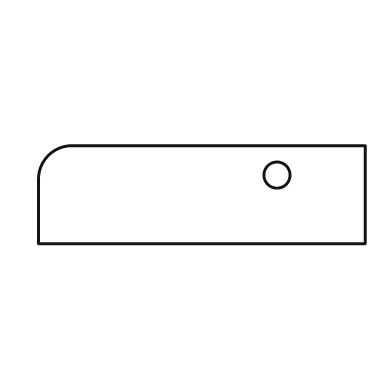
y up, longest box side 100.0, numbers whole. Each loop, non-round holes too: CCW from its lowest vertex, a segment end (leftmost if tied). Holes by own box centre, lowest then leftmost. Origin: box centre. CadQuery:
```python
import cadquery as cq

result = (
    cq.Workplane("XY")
    .moveTo(-50.0, -15.0)
    .lineTo(50.0, -15.0)
    .lineTo(50.0, 15.0)
    .lineTo(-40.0, 15.0)
    .threePointArc((-47.0, 12.0), (-50.0, 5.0))
    .close()
    .moveTo(23.0, 6.0)
    .circle(4.0)
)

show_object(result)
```